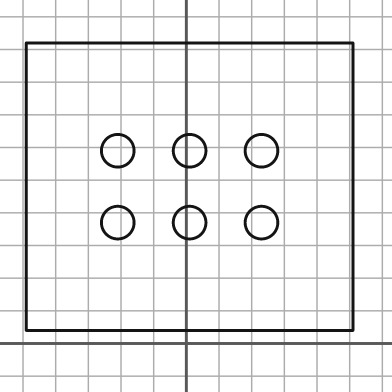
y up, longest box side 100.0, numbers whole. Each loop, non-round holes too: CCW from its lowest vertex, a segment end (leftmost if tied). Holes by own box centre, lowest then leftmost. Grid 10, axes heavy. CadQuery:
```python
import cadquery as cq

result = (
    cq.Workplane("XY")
    .moveTo(-49.0, 4.0)
    .lineTo(51.0, 4.0)
    .lineTo(51.0, 92.0)
    .lineTo(-49.0, 92.0)
    .close()
    .moveTo(-21.0, 37.0)
    .circle(5.0)
    .moveTo(1.0, 37.0)
    .circle(5.0)
    .moveTo(23.0, 37.0)
    .circle(5.0)
    .moveTo(-21.0, 59.0)
    .circle(5.0)
    .moveTo(1.0, 59.0)
    .circle(5.0)
    .moveTo(23.0, 59.0)
    .circle(5.0)
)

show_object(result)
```